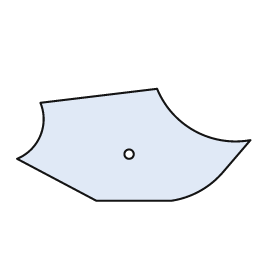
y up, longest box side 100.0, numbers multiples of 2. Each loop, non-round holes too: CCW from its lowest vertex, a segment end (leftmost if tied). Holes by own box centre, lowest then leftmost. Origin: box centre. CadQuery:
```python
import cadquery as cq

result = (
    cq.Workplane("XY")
    .moveTo(-16.0, -24.0)
    .lineTo(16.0, -24.0)
    .threePointArc((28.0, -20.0), (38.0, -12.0))
    .lineTo(50.0, 2.0)
    .threePointArc((26.0, 6.0), (10.0, 24.0))
    .lineTo(-40.0, 18.0)
    .threePointArc((-40.0, 4.0), (-50.0, -6.0))
    .close()
    .moveTo(-2.0, -4.0)
    .circle(2.0)
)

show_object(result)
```